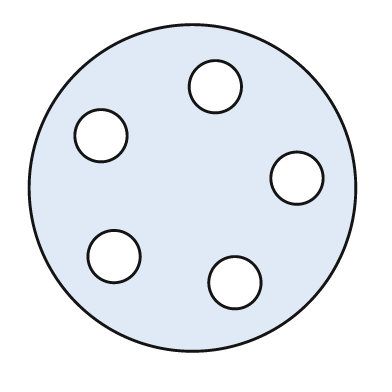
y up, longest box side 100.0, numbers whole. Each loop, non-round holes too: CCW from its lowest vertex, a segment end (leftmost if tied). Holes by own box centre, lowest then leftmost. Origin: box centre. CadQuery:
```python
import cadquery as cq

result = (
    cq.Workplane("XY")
    .moveTo(0.0, 0.0)
    .circle(50.0)
    .moveTo(13.0, -29.0)
    .circle(8.0)
    .moveTo(-24.0, -21.0)
    .circle(8.0)
    .moveTo(32.0, 3.0)
    .circle(8.0)
    .moveTo(-28.0, 16.0)
    .circle(8.0)
    .moveTo(7.0, 31.0)
    .circle(8.0)
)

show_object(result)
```